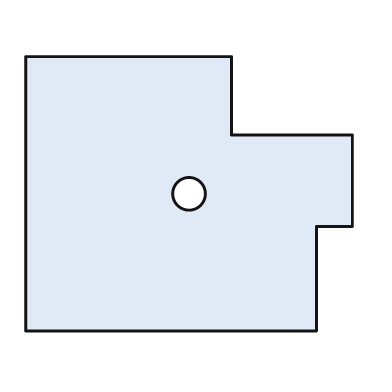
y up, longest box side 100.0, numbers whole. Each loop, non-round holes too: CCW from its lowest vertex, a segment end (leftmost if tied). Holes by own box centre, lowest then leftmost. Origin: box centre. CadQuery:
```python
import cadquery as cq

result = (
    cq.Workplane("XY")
    .moveTo(-50.0, -42.0)
    .lineTo(39.0, -42.0)
    .lineTo(39.0, -10.0)
    .lineTo(50.0, -10.0)
    .lineTo(50.0, 18.0)
    .lineTo(13.0, 18.0)
    .lineTo(13.0, 42.0)
    .lineTo(-50.0, 42.0)
    .close()
    .moveTo(0.0, 0.0)
    .circle(5.0)
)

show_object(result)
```